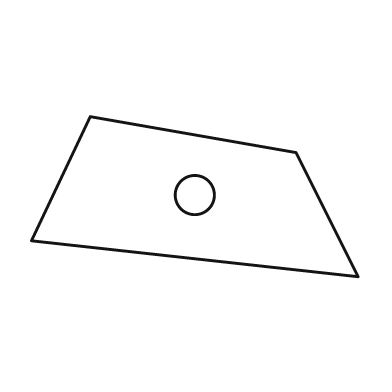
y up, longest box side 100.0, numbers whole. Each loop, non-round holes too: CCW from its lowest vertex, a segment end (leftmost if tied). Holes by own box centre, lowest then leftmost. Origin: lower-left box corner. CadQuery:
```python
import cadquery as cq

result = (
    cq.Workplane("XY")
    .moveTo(100.0, 0.0)
    .lineTo(81.0, 38.0)
    .lineTo(18.0, 49.0)
    .lineTo(0.0, 11.0)
    .close()
    .moveTo(50.0, 25.0)
    .circle(6.0)
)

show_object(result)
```